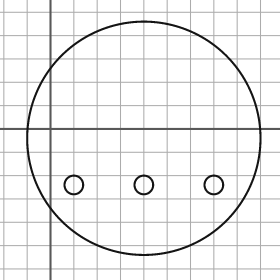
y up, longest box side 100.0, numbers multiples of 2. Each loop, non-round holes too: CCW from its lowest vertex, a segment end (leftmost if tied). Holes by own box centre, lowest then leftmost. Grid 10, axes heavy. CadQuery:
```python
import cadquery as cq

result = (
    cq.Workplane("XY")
    .moveTo(40.0, -4.0)
    .circle(50.0)
    .moveTo(10.0, -24.0)
    .circle(4.0)
    .moveTo(40.0, -24.0)
    .circle(4.0)
    .moveTo(70.0, -24.0)
    .circle(4.0)
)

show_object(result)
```